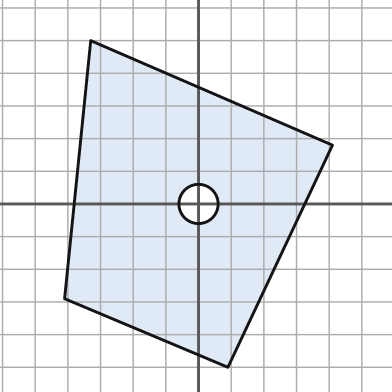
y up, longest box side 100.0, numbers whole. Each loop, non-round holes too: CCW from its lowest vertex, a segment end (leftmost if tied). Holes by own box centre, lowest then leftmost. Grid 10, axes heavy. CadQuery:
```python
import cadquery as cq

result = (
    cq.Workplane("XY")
    .moveTo(9.0, -50.0)
    .lineTo(41.0, 18.0)
    .lineTo(-33.0, 50.0)
    .lineTo(-41.0, -29.0)
    .close()
    .moveTo(0.0, 0.0)
    .circle(6.0)
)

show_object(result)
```